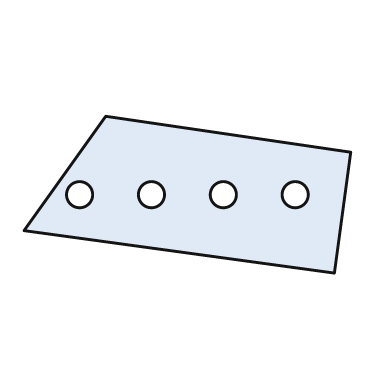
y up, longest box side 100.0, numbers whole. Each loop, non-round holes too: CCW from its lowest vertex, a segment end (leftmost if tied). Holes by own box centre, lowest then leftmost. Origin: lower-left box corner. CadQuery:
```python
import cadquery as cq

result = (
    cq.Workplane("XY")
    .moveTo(95.0, 0.0)
    .lineTo(100.0, 37.0)
    .lineTo(25.0, 48.0)
    .lineTo(0.0, 13.0)
    .close()
    .moveTo(17.0, 24.0)
    .circle(4.0)
    .moveTo(39.0, 24.0)
    .circle(4.0)
    .moveTo(61.0, 24.0)
    .circle(4.0)
    .moveTo(83.0, 24.0)
    .circle(4.0)
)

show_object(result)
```